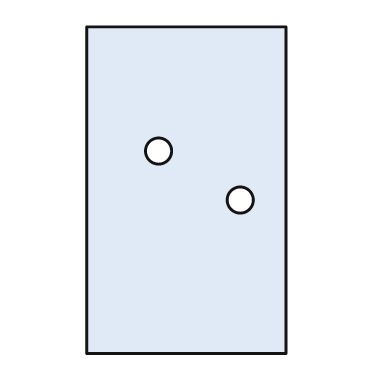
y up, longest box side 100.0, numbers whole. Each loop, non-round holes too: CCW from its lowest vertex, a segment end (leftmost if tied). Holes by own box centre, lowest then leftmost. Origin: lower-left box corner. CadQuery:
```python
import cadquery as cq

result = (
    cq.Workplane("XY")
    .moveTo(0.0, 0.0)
    .lineTo(61.0, 0.0)
    .lineTo(61.0, 100.0)
    .lineTo(0.0, 100.0)
    .close()
    .moveTo(47.0, 47.0)
    .circle(4.0)
    .moveTo(22.0, 62.0)
    .circle(4.0)
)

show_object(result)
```